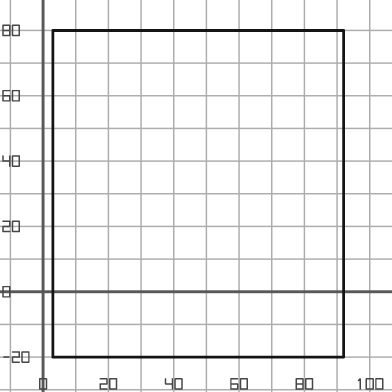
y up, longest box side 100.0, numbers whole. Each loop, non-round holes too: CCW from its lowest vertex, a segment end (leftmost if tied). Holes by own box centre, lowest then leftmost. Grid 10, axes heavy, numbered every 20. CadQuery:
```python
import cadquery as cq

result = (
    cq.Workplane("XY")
    .moveTo(3.0, -20.0)
    .lineTo(92.0, -20.0)
    .lineTo(92.0, 80.0)
    .lineTo(3.0, 80.0)
    .close()
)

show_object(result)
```